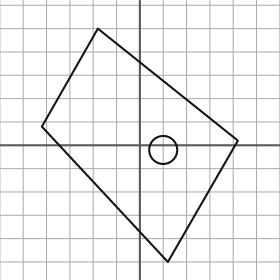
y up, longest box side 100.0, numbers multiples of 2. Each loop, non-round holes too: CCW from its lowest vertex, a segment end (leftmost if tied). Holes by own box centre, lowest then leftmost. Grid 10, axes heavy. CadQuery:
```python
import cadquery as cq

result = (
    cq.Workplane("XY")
    .moveTo(12.0, -50.0)
    .lineTo(42.0, 2.0)
    .lineTo(-18.0, 50.0)
    .lineTo(-42.0, 8.0)
    .close()
    .moveTo(10.0, -2.0)
    .circle(6.0)
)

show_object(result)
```